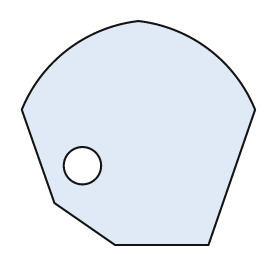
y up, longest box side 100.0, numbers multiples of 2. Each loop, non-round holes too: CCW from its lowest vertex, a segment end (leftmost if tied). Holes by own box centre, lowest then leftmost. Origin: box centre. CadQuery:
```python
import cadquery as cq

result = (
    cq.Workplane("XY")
    .moveTo(-10.0, -48.0)
    .lineTo(30.0, -48.0)
    .lineTo(50.0, 10.0)
    .threePointArc((30.0, 36.0), (0.0, 48.0))
    .threePointArc((-30.0, 36.0), (-50.0, 10.0))
    .lineTo(-36.0, -30.0)
    .close()
    .moveTo(-24.0, -14.0)
    .circle(8.0)
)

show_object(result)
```